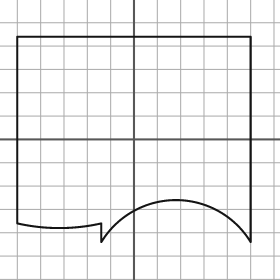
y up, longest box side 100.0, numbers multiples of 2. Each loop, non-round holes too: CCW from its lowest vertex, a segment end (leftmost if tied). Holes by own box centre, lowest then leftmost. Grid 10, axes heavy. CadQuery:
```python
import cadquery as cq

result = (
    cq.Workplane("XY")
    .moveTo(-14.0, -44.0)
    .threePointArc((18.0, -26.0), (50.0, -44.0))
    .lineTo(50.0, 44.0)
    .lineTo(-50.0, 44.0)
    .lineTo(-50.0, -36.0)
    .threePointArc((-32.0, -38.0), (-14.0, -36.0))
    .close()
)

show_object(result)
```